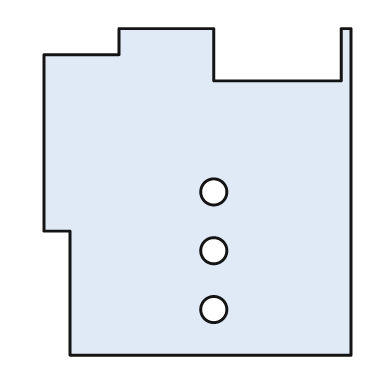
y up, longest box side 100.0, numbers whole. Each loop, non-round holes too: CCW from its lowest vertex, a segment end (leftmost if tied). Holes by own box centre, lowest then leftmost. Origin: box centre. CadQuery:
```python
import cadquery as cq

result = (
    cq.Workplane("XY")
    .moveTo(-39.0, -50.0)
    .lineTo(47.0, -50.0)
    .lineTo(47.0, 50.0)
    .lineTo(44.0, 50.0)
    .lineTo(44.0, 34.0)
    .lineTo(5.0, 34.0)
    .lineTo(5.0, 50.0)
    .lineTo(-24.0, 50.0)
    .lineTo(-24.0, 42.0)
    .lineTo(-47.0, 42.0)
    .lineTo(-47.0, -12.0)
    .lineTo(-39.0, -12.0)
    .close()
    .moveTo(5.0, -36.0)
    .circle(4.0)
    .moveTo(5.0, -18.0)
    .circle(4.0)
    .moveTo(5.0, 0.0)
    .circle(4.0)
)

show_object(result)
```